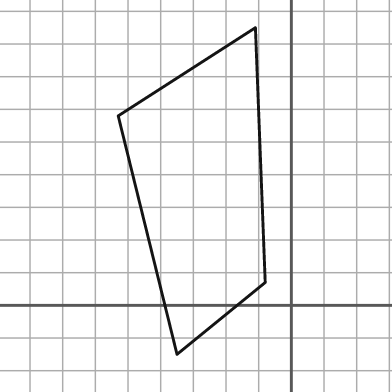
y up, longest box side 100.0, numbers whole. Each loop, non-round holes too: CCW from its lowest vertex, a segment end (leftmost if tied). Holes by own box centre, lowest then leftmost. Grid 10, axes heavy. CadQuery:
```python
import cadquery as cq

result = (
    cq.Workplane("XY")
    .moveTo(-35.0, -15.0)
    .lineTo(-8.0, 7.0)
    .lineTo(-11.0, 85.0)
    .lineTo(-53.0, 58.0)
    .close()
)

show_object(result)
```